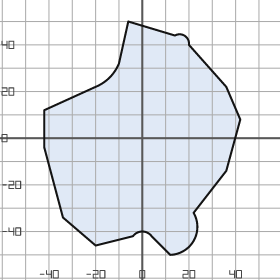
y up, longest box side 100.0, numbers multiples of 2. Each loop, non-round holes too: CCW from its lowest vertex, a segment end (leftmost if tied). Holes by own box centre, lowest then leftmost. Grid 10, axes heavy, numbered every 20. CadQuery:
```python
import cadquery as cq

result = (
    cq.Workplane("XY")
    .moveTo(12.0, -50.0)
    .threePointArc((22.0, -44.0), (22.0, -32.0))
    .lineTo(36.0, -14.0)
    .lineTo(42.0, 8.0)
    .lineTo(36.0, 22.0)
    .lineTo(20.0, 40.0)
    .threePointArc((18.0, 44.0), (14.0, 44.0))
    .lineTo(-6.0, 50.0)
    .lineTo(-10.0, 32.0)
    .threePointArc((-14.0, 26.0), (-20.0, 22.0))
    .lineTo(-42.0, 12.0)
    .lineTo(-42.0, -4.0)
    .lineTo(-34.0, -34.0)
    .lineTo(-20.0, -46.0)
    .lineTo(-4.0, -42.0)
    .threePointArc((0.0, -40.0), (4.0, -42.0))
    .close()
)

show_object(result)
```